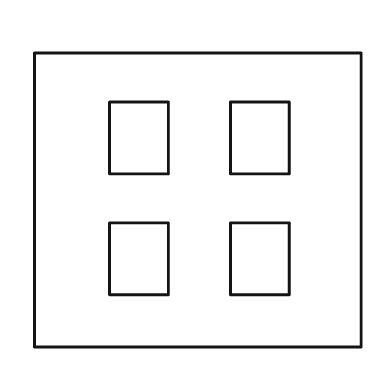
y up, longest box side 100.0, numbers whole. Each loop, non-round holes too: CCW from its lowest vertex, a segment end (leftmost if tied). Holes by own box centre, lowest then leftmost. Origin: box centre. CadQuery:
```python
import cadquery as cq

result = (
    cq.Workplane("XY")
    .moveTo(-50.0, -45.0)
    .lineTo(50.0, -45.0)
    .lineTo(50.0, 45.0)
    .lineTo(-50.0, 45.0)
    .close()
    .moveTo(-27.0, -29.0)
    .lineTo(-9.0, -29.0)
    .lineTo(-9.0, -7.0)
    .lineTo(-27.0, -7.0)
    .close()
    .moveTo(10.0, -29.0)
    .lineTo(28.0, -29.0)
    .lineTo(28.0, -7.0)
    .lineTo(10.0, -7.0)
    .close()
    .moveTo(-27.0, 8.0)
    .lineTo(-9.0, 8.0)
    .lineTo(-9.0, 30.0)
    .lineTo(-27.0, 30.0)
    .close()
    .moveTo(10.0, 8.0)
    .lineTo(28.0, 8.0)
    .lineTo(28.0, 30.0)
    .lineTo(10.0, 30.0)
    .close()
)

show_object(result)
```